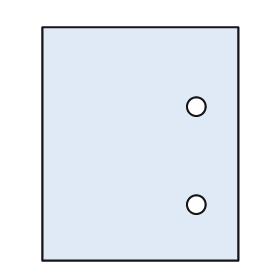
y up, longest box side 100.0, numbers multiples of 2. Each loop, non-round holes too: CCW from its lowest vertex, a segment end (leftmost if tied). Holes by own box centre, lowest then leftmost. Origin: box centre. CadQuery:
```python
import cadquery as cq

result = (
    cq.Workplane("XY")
    .moveTo(-42.0, -50.0)
    .lineTo(42.0, -50.0)
    .lineTo(42.0, 50.0)
    .lineTo(-42.0, 50.0)
    .close()
    .moveTo(24.0, -26.0)
    .circle(4.0)
    .moveTo(24.0, 16.0)
    .circle(4.0)
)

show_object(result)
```